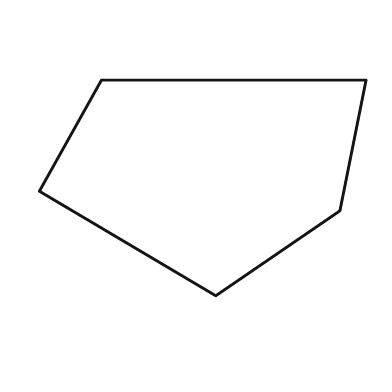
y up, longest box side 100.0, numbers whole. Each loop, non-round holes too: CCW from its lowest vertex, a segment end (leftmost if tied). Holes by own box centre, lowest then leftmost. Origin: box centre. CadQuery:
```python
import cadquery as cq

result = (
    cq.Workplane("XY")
    .moveTo(4.0, -33.0)
    .lineTo(42.0, -7.0)
    .lineTo(50.0, 33.0)
    .lineTo(-31.0, 33.0)
    .lineTo(-50.0, -1.0)
    .close()
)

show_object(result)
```